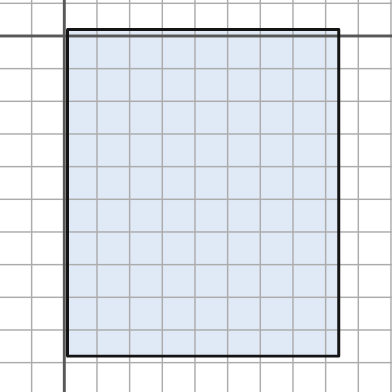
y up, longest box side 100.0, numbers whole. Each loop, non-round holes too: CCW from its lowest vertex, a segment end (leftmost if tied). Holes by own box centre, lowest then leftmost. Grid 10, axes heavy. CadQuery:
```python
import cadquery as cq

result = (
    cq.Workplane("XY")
    .moveTo(1.0, -98.0)
    .lineTo(84.0, -98.0)
    .lineTo(84.0, 2.0)
    .lineTo(1.0, 2.0)
    .close()
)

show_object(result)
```